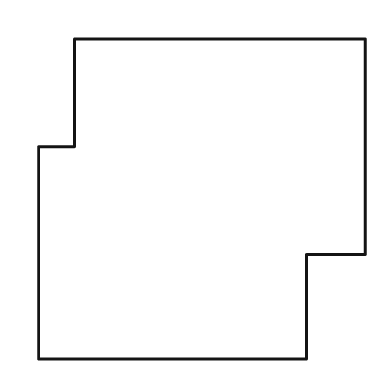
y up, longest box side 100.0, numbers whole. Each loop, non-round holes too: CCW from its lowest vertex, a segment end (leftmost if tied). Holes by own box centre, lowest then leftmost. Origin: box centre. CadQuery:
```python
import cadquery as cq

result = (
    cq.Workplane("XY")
    .moveTo(-50.0, -49.0)
    .lineTo(32.0, -49.0)
    .lineTo(32.0, -17.0)
    .lineTo(50.0, -17.0)
    .lineTo(50.0, 49.0)
    .lineTo(-39.0, 49.0)
    .lineTo(-39.0, 16.0)
    .lineTo(-50.0, 16.0)
    .close()
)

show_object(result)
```